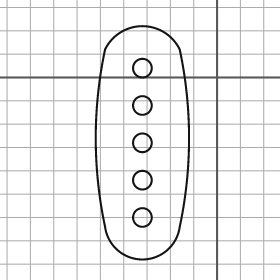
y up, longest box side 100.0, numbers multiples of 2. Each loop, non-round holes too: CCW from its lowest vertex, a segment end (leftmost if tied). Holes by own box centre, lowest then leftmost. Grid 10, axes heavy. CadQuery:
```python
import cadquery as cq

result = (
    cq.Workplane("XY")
    .moveTo(-48.0, -64.0)
    .threePointArc((-32.0, -78.0), (-16.0, -64.0))
    .threePointArc((-12.0, -26.0), (-16.0, 12.0))
    .threePointArc((-32.0, 22.0), (-48.0, 12.0))
    .threePointArc((-52.0, -26.0), (-48.0, -64.0))
    .close()
    .moveTo(-32.0, -60.0)
    .circle(4.0)
    .moveTo(-32.0, -44.0)
    .circle(4.0)
    .moveTo(-32.0, -28.0)
    .circle(4.0)
    .moveTo(-32.0, -12.0)
    .circle(4.0)
    .moveTo(-32.0, 4.0)
    .circle(4.0)
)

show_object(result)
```